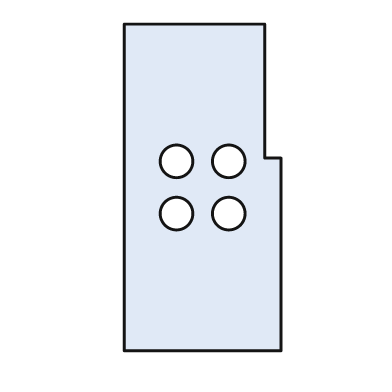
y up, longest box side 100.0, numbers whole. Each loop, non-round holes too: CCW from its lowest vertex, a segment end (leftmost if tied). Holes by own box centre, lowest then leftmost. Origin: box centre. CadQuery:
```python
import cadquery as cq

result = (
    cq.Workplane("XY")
    .moveTo(-24.0, -50.0)
    .lineTo(24.0, -50.0)
    .lineTo(24.0, 9.0)
    .lineTo(19.0, 9.0)
    .lineTo(19.0, 50.0)
    .lineTo(-24.0, 50.0)
    .close()
    .moveTo(-8.0, -8.0)
    .circle(5.0)
    .moveTo(8.0, -8.0)
    .circle(5.0)
    .moveTo(-8.0, 8.0)
    .circle(5.0)
    .moveTo(8.0, 8.0)
    .circle(5.0)
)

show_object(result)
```